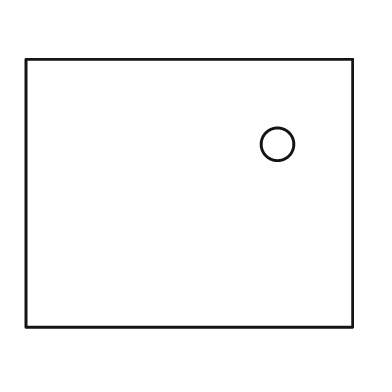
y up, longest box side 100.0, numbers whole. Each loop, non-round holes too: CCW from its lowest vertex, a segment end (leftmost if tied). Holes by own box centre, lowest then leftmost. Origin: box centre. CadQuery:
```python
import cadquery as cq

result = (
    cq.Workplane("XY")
    .moveTo(-50.0, -41.0)
    .lineTo(50.0, -41.0)
    .lineTo(50.0, 41.0)
    .lineTo(-50.0, 41.0)
    .close()
    .moveTo(27.0, 15.0)
    .circle(5.0)
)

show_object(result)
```